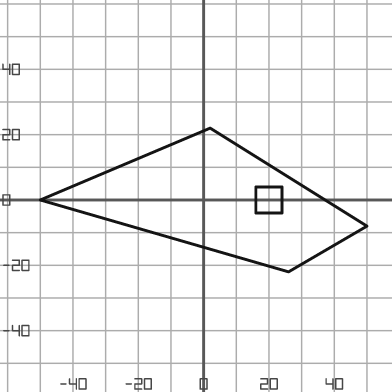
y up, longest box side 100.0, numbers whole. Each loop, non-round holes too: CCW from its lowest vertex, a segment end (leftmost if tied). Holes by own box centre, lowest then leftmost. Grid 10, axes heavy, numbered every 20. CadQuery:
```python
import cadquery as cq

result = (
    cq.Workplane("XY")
    .moveTo(26.0, -22.0)
    .lineTo(50.0, -8.0)
    .lineTo(2.0, 22.0)
    .lineTo(-50.0, 0.0)
    .close()
    .moveTo(16.0, -4.0)
    .lineTo(24.0, -4.0)
    .lineTo(24.0, 4.0)
    .lineTo(16.0, 4.0)
    .close()
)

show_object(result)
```